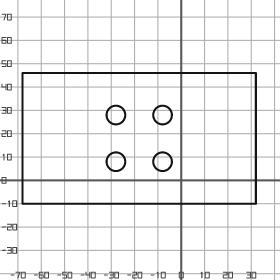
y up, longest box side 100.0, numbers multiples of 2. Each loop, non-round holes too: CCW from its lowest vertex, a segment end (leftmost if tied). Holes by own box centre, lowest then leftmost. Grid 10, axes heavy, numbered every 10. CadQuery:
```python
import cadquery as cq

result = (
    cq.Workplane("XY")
    .moveTo(-68.0, -10.0)
    .lineTo(32.0, -10.0)
    .lineTo(32.0, 46.0)
    .lineTo(-68.0, 46.0)
    .close()
    .moveTo(-28.0, 8.0)
    .circle(4.0)
    .moveTo(-8.0, 8.0)
    .circle(4.0)
    .moveTo(-28.0, 28.0)
    .circle(4.0)
    .moveTo(-8.0, 28.0)
    .circle(4.0)
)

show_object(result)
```